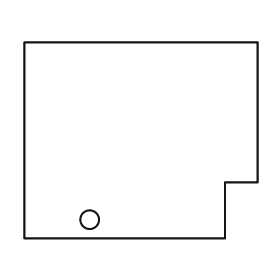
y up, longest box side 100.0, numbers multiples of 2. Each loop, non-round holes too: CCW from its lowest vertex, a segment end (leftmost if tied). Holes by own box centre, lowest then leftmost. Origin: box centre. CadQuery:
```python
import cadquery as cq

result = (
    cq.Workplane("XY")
    .moveTo(-50.0, -42.0)
    .lineTo(36.0, -42.0)
    .lineTo(36.0, -18.0)
    .lineTo(50.0, -18.0)
    .lineTo(50.0, 42.0)
    .lineTo(-50.0, 42.0)
    .close()
    .moveTo(-22.0, -34.0)
    .circle(4.0)
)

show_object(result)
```